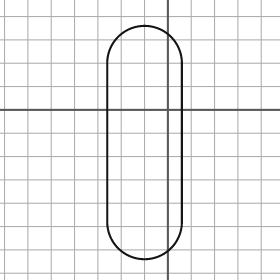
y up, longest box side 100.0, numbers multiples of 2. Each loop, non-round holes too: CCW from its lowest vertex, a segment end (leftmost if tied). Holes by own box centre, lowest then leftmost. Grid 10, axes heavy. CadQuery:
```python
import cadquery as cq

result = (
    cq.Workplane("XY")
    .moveTo(-26.0, -48.0)
    .threePointArc((-10.0, -64.0), (6.0, -48.0))
    .lineTo(6.0, 20.0)
    .threePointArc((-10.0, 36.0), (-26.0, 20.0))
    .close()
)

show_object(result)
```